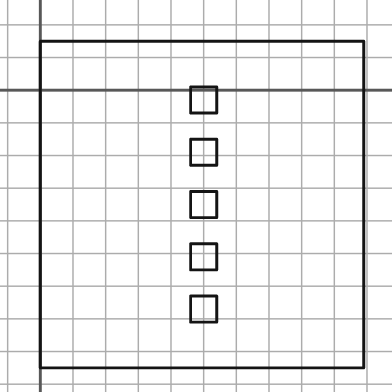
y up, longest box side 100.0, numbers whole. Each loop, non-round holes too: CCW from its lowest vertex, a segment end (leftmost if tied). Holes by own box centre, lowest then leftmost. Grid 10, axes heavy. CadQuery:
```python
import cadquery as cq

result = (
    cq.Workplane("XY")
    .moveTo(0.0, -85.0)
    .lineTo(99.0, -85.0)
    .lineTo(99.0, 15.0)
    .lineTo(0.0, 15.0)
    .close()
    .moveTo(46.0, -71.0)
    .lineTo(54.0, -71.0)
    .lineTo(54.0, -63.0)
    .lineTo(46.0, -63.0)
    .close()
    .moveTo(46.0, -55.0)
    .lineTo(54.0, -55.0)
    .lineTo(54.0, -47.0)
    .lineTo(46.0, -47.0)
    .close()
    .moveTo(46.0, -39.0)
    .lineTo(54.0, -39.0)
    .lineTo(54.0, -31.0)
    .lineTo(46.0, -31.0)
    .close()
    .moveTo(46.0, -23.0)
    .lineTo(54.0, -23.0)
    .lineTo(54.0, -15.0)
    .lineTo(46.0, -15.0)
    .close()
    .moveTo(46.0, -7.0)
    .lineTo(54.0, -7.0)
    .lineTo(54.0, 1.0)
    .lineTo(46.0, 1.0)
    .close()
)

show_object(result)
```